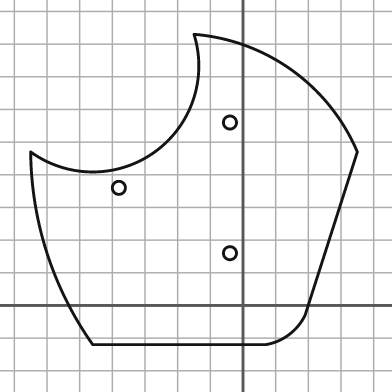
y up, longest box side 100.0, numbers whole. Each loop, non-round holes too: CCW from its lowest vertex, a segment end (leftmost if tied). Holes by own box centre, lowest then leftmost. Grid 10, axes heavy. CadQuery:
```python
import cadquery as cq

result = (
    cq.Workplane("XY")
    .moveTo(-46.0, -12.0)
    .lineTo(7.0, -12.0)
    .threePointArc((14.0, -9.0), (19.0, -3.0))
    .lineTo(35.0, 47.0)
    .threePointArc((15.0, 72.0), (-15.0, 83.0))
    .threePointArc((-27.0, 47.0), (-65.0, 47.0))
    .threePointArc((-60.0, 16.0), (-46.0, -12.0))
    .close()
    .moveTo(-4.0, 16.0)
    .circle(2.0)
    .moveTo(-38.0, 36.0)
    .circle(2.0)
    .moveTo(-4.0, 56.0)
    .circle(2.0)
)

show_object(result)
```